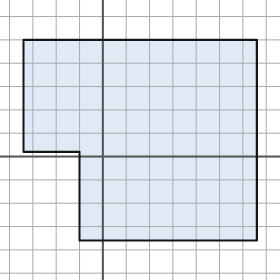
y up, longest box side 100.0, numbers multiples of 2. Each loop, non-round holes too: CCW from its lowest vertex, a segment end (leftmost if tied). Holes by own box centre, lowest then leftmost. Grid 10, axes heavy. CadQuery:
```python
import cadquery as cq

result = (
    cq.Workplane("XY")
    .moveTo(-10.0, -36.0)
    .lineTo(66.0, -36.0)
    .lineTo(66.0, 50.0)
    .lineTo(-34.0, 50.0)
    .lineTo(-34.0, 2.0)
    .lineTo(-10.0, 2.0)
    .close()
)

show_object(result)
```